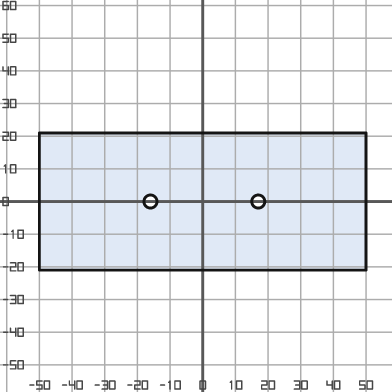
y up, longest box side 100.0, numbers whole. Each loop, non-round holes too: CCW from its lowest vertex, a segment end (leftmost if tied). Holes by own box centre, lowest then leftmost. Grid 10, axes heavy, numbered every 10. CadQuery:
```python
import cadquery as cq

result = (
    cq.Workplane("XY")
    .moveTo(-50.0, -21.0)
    .lineTo(50.0, -21.0)
    .lineTo(50.0, 21.0)
    .lineTo(-50.0, 21.0)
    .close()
    .moveTo(-16.0, 0.0)
    .circle(2.0)
    .moveTo(17.0, 0.0)
    .circle(2.0)
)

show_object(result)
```